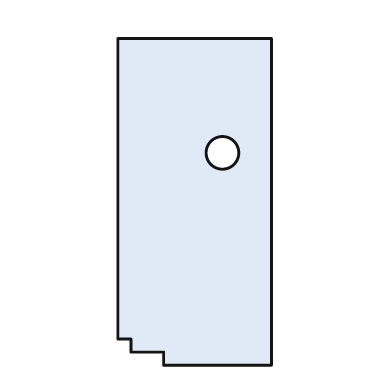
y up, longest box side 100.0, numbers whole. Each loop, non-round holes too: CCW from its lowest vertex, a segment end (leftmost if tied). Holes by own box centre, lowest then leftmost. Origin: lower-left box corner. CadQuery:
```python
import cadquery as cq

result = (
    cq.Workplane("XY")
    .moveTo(14.0, 0.0)
    .lineTo(47.0, 0.0)
    .lineTo(47.0, 100.0)
    .lineTo(0.0, 100.0)
    .lineTo(0.0, 8.0)
    .lineTo(4.0, 8.0)
    .lineTo(4.0, 4.0)
    .lineTo(14.0, 4.0)
    .close()
    .moveTo(32.0, 65.0)
    .circle(5.0)
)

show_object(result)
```